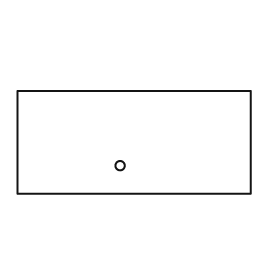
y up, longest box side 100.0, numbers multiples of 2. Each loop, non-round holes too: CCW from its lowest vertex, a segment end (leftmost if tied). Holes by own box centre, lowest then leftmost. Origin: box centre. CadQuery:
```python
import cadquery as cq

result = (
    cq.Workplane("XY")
    .moveTo(-50.0, -22.0)
    .lineTo(50.0, -22.0)
    .lineTo(50.0, 22.0)
    .lineTo(-50.0, 22.0)
    .close()
    .moveTo(-6.0, -10.0)
    .circle(2.0)
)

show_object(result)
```